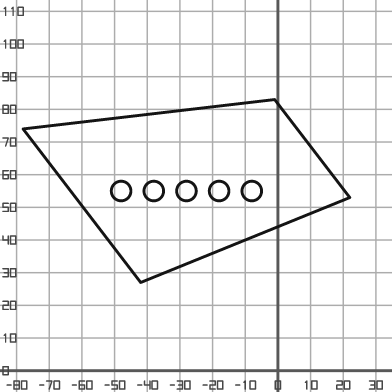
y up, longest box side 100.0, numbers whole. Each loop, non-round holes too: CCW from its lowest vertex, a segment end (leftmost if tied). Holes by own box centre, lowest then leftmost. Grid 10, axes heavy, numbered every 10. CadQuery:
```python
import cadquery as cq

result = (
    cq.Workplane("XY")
    .moveTo(-42.0, 27.0)
    .lineTo(22.0, 53.0)
    .lineTo(-1.0, 83.0)
    .lineTo(-78.0, 74.0)
    .close()
    .moveTo(-48.0, 55.0)
    .circle(3.0)
    .moveTo(-38.0, 55.0)
    .circle(3.0)
    .moveTo(-28.0, 55.0)
    .circle(3.0)
    .moveTo(-18.0, 55.0)
    .circle(3.0)
    .moveTo(-8.0, 55.0)
    .circle(3.0)
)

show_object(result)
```